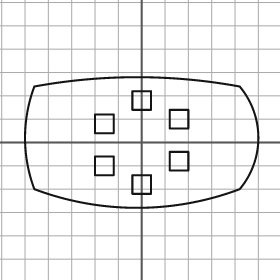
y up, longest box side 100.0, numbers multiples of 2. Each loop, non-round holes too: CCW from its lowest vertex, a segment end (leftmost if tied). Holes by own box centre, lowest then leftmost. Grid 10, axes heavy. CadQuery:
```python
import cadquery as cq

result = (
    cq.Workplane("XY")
    .moveTo(-46.0, -20.0)
    .threePointArc((-2.0, -28.0), (42.0, -20.0))
    .threePointArc((50.0, 2.0), (42.0, 24.0))
    .threePointArc((-2.0, 28.0), (-46.0, 24.0))
    .threePointArc((-50.0, 2.0), (-46.0, -20.0))
    .close()
    .moveTo(-4.0, -22.0)
    .lineTo(4.0, -22.0)
    .lineTo(4.0, -14.0)
    .lineTo(-4.0, -14.0)
    .close()
    .moveTo(-20.0, -14.0)
    .lineTo(-12.0, -14.0)
    .lineTo(-12.0, -6.0)
    .lineTo(-20.0, -6.0)
    .close()
    .moveTo(12.0, -12.0)
    .lineTo(20.0, -12.0)
    .lineTo(20.0, -4.0)
    .lineTo(12.0, -4.0)
    .close()
    .moveTo(-20.0, 4.0)
    .lineTo(-12.0, 4.0)
    .lineTo(-12.0, 12.0)
    .lineTo(-20.0, 12.0)
    .close()
    .moveTo(12.0, 6.0)
    .lineTo(20.0, 6.0)
    .lineTo(20.0, 14.0)
    .lineTo(12.0, 14.0)
    .close()
    .moveTo(-4.0, 14.0)
    .lineTo(4.0, 14.0)
    .lineTo(4.0, 22.0)
    .lineTo(-4.0, 22.0)
    .close()
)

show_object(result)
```